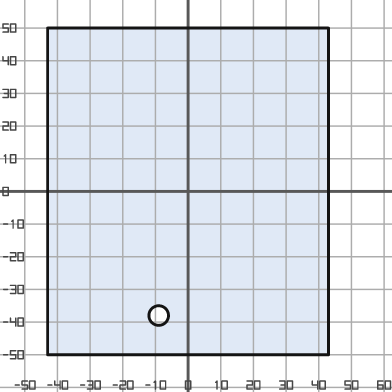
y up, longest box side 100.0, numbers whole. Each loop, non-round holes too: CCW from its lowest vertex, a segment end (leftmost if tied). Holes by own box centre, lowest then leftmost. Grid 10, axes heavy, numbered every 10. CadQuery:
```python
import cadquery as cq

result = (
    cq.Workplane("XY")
    .moveTo(-43.0, -50.0)
    .lineTo(43.0, -50.0)
    .lineTo(43.0, 50.0)
    .lineTo(-43.0, 50.0)
    .close()
    .moveTo(-9.0, -38.0)
    .circle(3.0)
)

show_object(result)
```